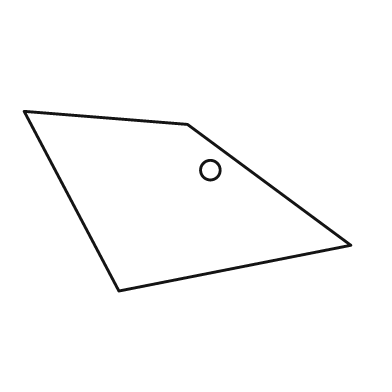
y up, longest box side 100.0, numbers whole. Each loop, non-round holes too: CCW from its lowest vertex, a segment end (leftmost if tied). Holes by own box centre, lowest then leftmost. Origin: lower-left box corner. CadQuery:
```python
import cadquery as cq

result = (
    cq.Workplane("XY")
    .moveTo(29.0, 0.0)
    .lineTo(100.0, 14.0)
    .lineTo(50.0, 51.0)
    .lineTo(0.0, 55.0)
    .close()
    .moveTo(57.0, 37.0)
    .circle(3.0)
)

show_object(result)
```